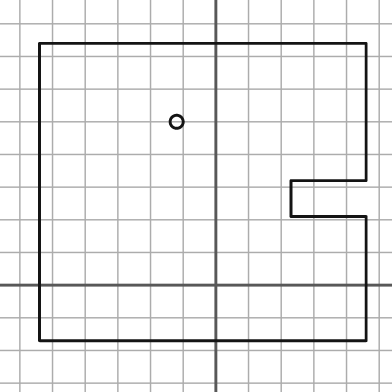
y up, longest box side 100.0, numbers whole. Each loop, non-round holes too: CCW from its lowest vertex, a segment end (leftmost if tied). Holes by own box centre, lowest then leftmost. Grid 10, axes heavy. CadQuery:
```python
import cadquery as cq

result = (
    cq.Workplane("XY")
    .moveTo(-54.0, -17.0)
    .lineTo(46.0, -17.0)
    .lineTo(46.0, 21.0)
    .lineTo(23.0, 21.0)
    .lineTo(23.0, 32.0)
    .lineTo(46.0, 32.0)
    .lineTo(46.0, 74.0)
    .lineTo(-54.0, 74.0)
    .close()
    .moveTo(-12.0, 50.0)
    .circle(2.0)
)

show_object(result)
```